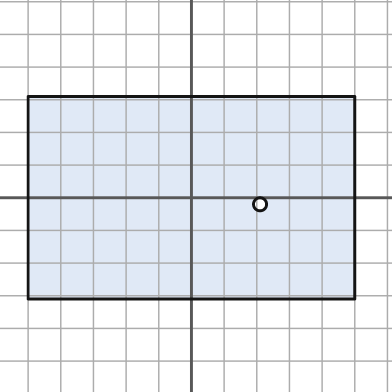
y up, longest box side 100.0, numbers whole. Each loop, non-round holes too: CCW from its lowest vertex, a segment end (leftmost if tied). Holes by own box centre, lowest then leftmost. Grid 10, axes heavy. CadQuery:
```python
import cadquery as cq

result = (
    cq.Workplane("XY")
    .moveTo(-50.0, -31.0)
    .lineTo(50.0, -31.0)
    .lineTo(50.0, 31.0)
    .lineTo(-50.0, 31.0)
    .close()
    .moveTo(21.0, -2.0)
    .circle(2.0)
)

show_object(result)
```